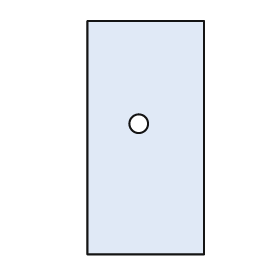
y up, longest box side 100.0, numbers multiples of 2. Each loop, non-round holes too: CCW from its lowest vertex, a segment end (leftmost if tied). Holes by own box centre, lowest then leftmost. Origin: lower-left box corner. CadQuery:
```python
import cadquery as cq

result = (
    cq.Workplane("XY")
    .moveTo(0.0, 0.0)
    .lineTo(50.0, 0.0)
    .lineTo(50.0, 100.0)
    .lineTo(0.0, 100.0)
    .close()
    .moveTo(22.0, 56.0)
    .circle(4.0)
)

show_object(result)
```